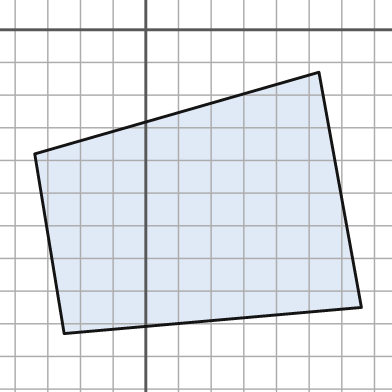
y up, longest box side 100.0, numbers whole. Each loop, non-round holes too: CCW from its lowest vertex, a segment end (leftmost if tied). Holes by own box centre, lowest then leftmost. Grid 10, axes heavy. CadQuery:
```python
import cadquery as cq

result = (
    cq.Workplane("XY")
    .moveTo(-25.0, -93.0)
    .lineTo(66.0, -85.0)
    .lineTo(53.0, -13.0)
    .lineTo(-34.0, -38.0)
    .close()
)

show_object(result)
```